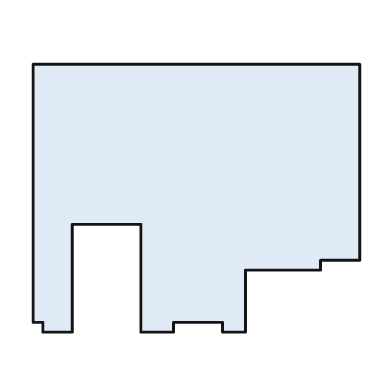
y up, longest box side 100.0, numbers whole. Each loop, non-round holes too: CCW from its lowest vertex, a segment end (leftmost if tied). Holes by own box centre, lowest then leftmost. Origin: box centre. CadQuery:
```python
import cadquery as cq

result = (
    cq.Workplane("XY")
    .moveTo(-47.0, -41.0)
    .lineTo(-38.0, -41.0)
    .lineTo(-38.0, -8.0)
    .lineTo(-17.0, -8.0)
    .lineTo(-17.0, -41.0)
    .lineTo(-7.0, -41.0)
    .lineTo(-7.0, -38.0)
    .lineTo(8.0, -38.0)
    .lineTo(8.0, -41.0)
    .lineTo(15.0, -41.0)
    .lineTo(15.0, -22.0)
    .lineTo(38.0, -22.0)
    .lineTo(38.0, -19.0)
    .lineTo(50.0, -19.0)
    .lineTo(50.0, 41.0)
    .lineTo(-50.0, 41.0)
    .lineTo(-50.0, -38.0)
    .lineTo(-47.0, -38.0)
    .close()
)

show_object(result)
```